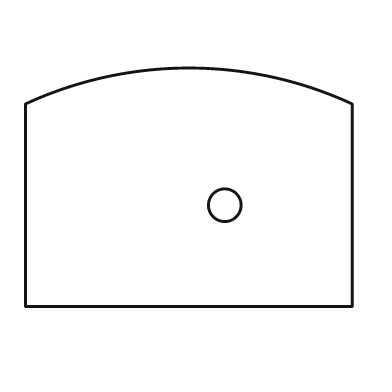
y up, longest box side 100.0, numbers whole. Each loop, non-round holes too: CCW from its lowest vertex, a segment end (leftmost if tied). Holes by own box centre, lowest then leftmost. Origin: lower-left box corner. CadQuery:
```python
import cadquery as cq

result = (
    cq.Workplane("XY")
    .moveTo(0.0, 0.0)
    .lineTo(100.0, 0.0)
    .lineTo(100.0, 62.0)
    .threePointArc((50.0, 73.0), (0.0, 62.0))
    .close()
    .moveTo(61.0, 31.0)
    .circle(5.0)
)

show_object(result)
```